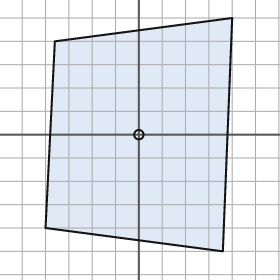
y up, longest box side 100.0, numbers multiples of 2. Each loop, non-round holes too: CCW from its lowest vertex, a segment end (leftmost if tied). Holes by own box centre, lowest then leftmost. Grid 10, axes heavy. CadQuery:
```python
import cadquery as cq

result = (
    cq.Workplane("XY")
    .moveTo(36.0, -50.0)
    .lineTo(40.0, 50.0)
    .lineTo(-36.0, 40.0)
    .lineTo(-40.0, -40.0)
    .close()
    .moveTo(0.0, 0.0)
    .circle(2.0)
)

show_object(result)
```